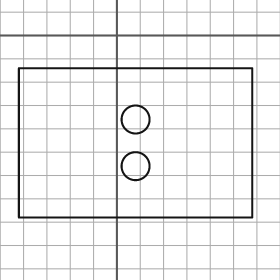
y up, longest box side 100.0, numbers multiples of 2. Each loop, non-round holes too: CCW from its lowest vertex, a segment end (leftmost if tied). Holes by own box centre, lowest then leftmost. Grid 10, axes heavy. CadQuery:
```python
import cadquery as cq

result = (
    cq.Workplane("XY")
    .moveTo(-42.0, -78.0)
    .lineTo(58.0, -78.0)
    .lineTo(58.0, -14.0)
    .lineTo(-42.0, -14.0)
    .close()
    .moveTo(8.0, -56.0)
    .circle(6.0)
    .moveTo(8.0, -36.0)
    .circle(6.0)
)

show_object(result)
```